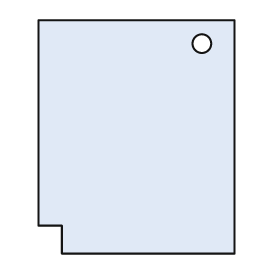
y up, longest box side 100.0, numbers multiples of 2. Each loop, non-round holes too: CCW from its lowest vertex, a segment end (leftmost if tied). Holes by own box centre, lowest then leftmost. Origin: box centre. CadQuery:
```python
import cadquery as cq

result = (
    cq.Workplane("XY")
    .moveTo(-32.0, -50.0)
    .lineTo(42.0, -50.0)
    .lineTo(42.0, 50.0)
    .lineTo(-42.0, 50.0)
    .lineTo(-42.0, -38.0)
    .lineTo(-32.0, -38.0)
    .close()
    .moveTo(28.0, 40.0)
    .circle(4.0)
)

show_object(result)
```